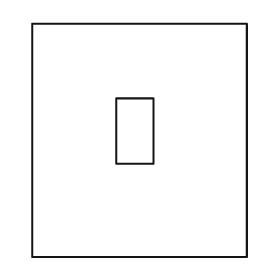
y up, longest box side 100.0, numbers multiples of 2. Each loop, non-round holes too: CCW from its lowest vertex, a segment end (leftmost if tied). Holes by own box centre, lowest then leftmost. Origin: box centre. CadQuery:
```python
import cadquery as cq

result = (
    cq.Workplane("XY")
    .moveTo(-46.0, -50.0)
    .lineTo(46.0, -50.0)
    .lineTo(46.0, 50.0)
    .lineTo(-46.0, 50.0)
    .close()
    .moveTo(-10.0, -10.0)
    .lineTo(6.0, -10.0)
    .lineTo(6.0, 18.0)
    .lineTo(-10.0, 18.0)
    .close()
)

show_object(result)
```